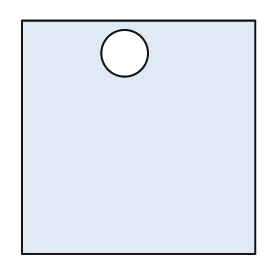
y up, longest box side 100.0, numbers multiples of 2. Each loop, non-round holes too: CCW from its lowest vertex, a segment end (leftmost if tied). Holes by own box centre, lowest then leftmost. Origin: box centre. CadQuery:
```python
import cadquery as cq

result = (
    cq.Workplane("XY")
    .moveTo(-50.0, -50.0)
    .lineTo(50.0, -50.0)
    .lineTo(50.0, 50.0)
    .lineTo(-50.0, 50.0)
    .close()
    .moveTo(-6.0, 36.0)
    .circle(10.0)
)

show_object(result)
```